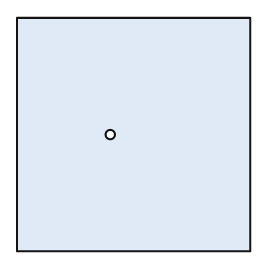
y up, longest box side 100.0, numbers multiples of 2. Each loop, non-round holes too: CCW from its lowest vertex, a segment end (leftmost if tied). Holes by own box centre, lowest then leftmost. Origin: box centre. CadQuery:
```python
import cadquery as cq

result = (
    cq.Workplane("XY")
    .moveTo(-50.0, -50.0)
    .lineTo(50.0, -50.0)
    .lineTo(50.0, 50.0)
    .lineTo(-50.0, 50.0)
    .close()
    .moveTo(-10.0, 0.0)
    .circle(2.0)
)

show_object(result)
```